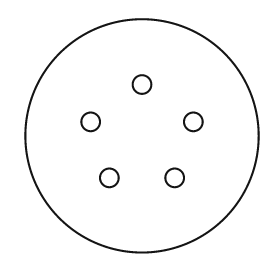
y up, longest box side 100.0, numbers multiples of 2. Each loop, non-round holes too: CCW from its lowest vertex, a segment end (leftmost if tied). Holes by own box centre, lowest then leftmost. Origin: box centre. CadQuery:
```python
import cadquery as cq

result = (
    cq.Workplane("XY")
    .moveTo(0.0, 0.0)
    .circle(50.0)
    .moveTo(-14.0, -18.0)
    .circle(4.0)
    .moveTo(14.0, -18.0)
    .circle(4.0)
    .moveTo(-22.0, 6.0)
    .circle(4.0)
    .moveTo(22.0, 6.0)
    .circle(4.0)
    .moveTo(0.0, 22.0)
    .circle(4.0)
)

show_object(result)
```